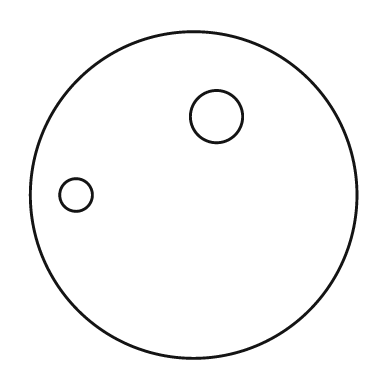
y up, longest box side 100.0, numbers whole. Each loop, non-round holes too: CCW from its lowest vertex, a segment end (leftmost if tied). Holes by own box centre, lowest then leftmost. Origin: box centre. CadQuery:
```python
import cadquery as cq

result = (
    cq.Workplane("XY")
    .moveTo(0.0, 0.0)
    .circle(50.0)
    .moveTo(-36.0, 0.0)
    .circle(5.0)
    .moveTo(7.0, 24.0)
    .circle(8.0)
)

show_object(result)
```